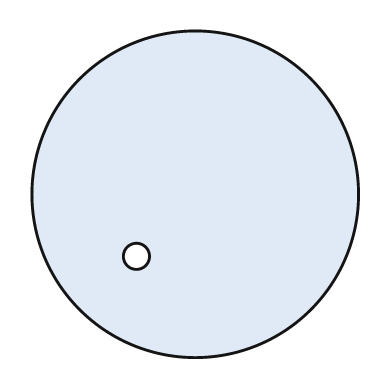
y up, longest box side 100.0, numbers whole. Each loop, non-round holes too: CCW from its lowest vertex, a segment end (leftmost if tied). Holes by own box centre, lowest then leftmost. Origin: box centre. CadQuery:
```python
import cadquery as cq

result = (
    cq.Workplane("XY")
    .moveTo(0.0, 0.0)
    .circle(50.0)
    .moveTo(-18.0, -19.0)
    .circle(4.0)
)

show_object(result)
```